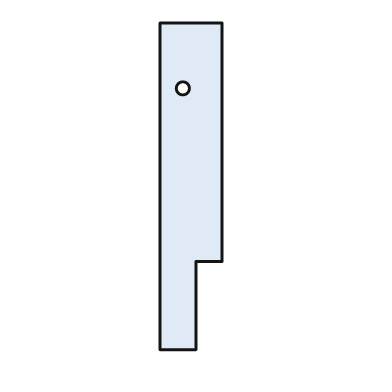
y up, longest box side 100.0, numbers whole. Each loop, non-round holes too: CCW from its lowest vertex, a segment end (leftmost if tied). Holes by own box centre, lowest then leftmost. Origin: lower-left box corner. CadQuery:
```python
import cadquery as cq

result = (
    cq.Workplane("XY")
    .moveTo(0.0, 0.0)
    .lineTo(11.0, 0.0)
    .lineTo(11.0, 27.0)
    .lineTo(19.0, 27.0)
    .lineTo(19.0, 100.0)
    .lineTo(0.0, 100.0)
    .close()
    .moveTo(7.0, 80.0)
    .circle(2.0)
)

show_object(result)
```